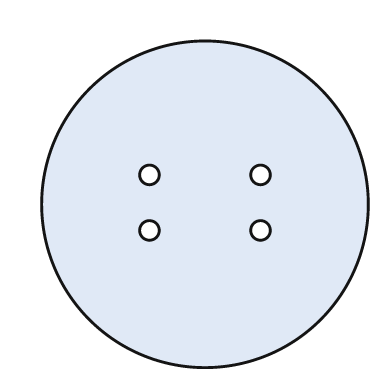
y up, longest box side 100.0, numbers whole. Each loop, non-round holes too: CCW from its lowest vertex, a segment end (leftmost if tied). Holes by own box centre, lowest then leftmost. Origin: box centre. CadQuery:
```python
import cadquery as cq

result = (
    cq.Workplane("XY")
    .moveTo(0.0, 0.0)
    .circle(50.0)
    .moveTo(-17.0, -8.0)
    .circle(3.0)
    .moveTo(17.0, -8.0)
    .circle(3.0)
    .moveTo(-17.0, 9.0)
    .circle(3.0)
    .moveTo(17.0, 9.0)
    .circle(3.0)
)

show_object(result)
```